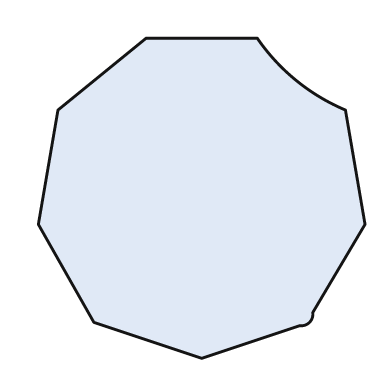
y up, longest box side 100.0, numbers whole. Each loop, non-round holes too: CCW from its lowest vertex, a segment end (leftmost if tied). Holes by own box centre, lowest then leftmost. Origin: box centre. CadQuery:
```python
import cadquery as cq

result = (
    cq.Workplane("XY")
    .moveTo(0.0, -49.0)
    .lineTo(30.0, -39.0)
    .threePointArc((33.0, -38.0), (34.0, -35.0))
    .lineTo(50.0, -8.0)
    .lineTo(44.0, 27.0)
    .threePointArc((29.0, 36.0), (17.0, 49.0))
    .lineTo(-17.0, 49.0)
    .lineTo(-44.0, 27.0)
    .lineTo(-50.0, -8.0)
    .lineTo(-33.0, -38.0)
    .close()
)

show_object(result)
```